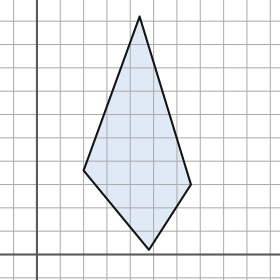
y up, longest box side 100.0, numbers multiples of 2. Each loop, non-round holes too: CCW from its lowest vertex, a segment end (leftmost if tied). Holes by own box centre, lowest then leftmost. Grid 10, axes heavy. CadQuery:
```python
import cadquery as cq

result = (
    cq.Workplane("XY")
    .moveTo(48.0, 2.0)
    .lineTo(66.0, 30.0)
    .lineTo(44.0, 102.0)
    .lineTo(20.0, 36.0)
    .close()
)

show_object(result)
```